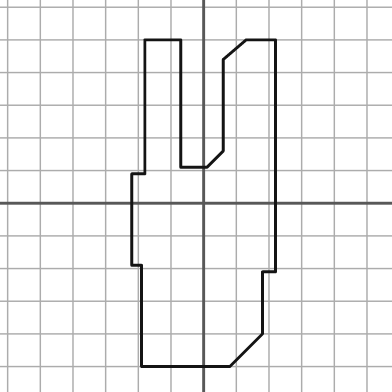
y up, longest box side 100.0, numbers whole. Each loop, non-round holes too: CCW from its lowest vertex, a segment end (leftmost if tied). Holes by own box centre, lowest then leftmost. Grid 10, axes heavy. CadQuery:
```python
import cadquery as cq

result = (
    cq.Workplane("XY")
    .moveTo(-19.0, -50.0)
    .lineTo(8.0, -50.0)
    .lineTo(18.0, -40.0)
    .lineTo(18.0, -21.0)
    .lineTo(22.0, -21.0)
    .lineTo(22.0, 50.0)
    .lineTo(13.0, 50.0)
    .lineTo(6.0, 44.0)
    .lineTo(6.0, 16.0)
    .lineTo(1.0, 11.0)
    .lineTo(-7.0, 11.0)
    .lineTo(-7.0, 50.0)
    .lineTo(-18.0, 50.0)
    .lineTo(-18.0, 9.0)
    .lineTo(-22.0, 9.0)
    .lineTo(-22.0, -19.0)
    .lineTo(-19.0, -19.0)
    .close()
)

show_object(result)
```